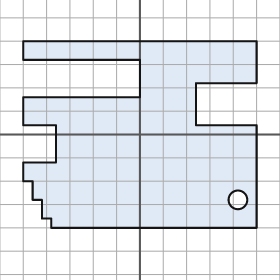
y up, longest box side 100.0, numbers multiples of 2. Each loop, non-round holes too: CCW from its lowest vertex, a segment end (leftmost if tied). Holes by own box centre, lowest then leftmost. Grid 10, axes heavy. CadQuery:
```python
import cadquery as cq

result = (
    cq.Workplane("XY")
    .moveTo(-38.0, -40.0)
    .lineTo(50.0, -40.0)
    .lineTo(50.0, 4.0)
    .lineTo(24.0, 4.0)
    .lineTo(24.0, 22.0)
    .lineTo(50.0, 22.0)
    .lineTo(50.0, 40.0)
    .lineTo(-50.0, 40.0)
    .lineTo(-50.0, 32.0)
    .lineTo(0.0, 32.0)
    .lineTo(0.0, 16.0)
    .lineTo(-50.0, 16.0)
    .lineTo(-50.0, 4.0)
    .lineTo(-36.0, 4.0)
    .lineTo(-36.0, -12.0)
    .lineTo(-50.0, -12.0)
    .lineTo(-50.0, -20.0)
    .lineTo(-46.0, -20.0)
    .lineTo(-46.0, -28.0)
    .lineTo(-42.0, -28.0)
    .lineTo(-42.0, -36.0)
    .lineTo(-38.0, -36.0)
    .close()
    .moveTo(42.0, -28.0)
    .circle(4.0)
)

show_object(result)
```